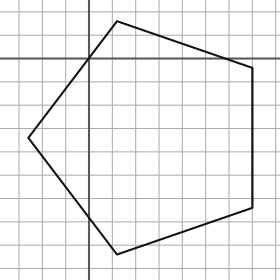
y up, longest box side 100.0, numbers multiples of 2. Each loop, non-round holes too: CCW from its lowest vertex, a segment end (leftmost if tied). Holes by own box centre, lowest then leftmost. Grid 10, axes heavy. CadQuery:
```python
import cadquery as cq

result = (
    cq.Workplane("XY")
    .moveTo(12.0, -84.0)
    .lineTo(70.0, -64.0)
    .lineTo(70.0, -4.0)
    .lineTo(12.0, 16.0)
    .lineTo(-26.0, -34.0)
    .close()
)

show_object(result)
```